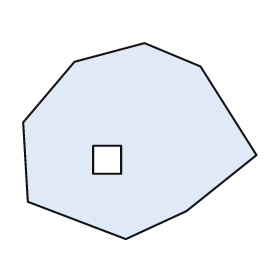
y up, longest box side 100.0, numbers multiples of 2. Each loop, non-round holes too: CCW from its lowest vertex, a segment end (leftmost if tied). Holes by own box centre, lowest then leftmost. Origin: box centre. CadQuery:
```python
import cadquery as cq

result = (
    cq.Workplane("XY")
    .moveTo(-6.0, -42.0)
    .lineTo(20.0, -30.0)
    .lineTo(50.0, -6.0)
    .lineTo(26.0, 32.0)
    .lineTo(2.0, 42.0)
    .lineTo(-28.0, 34.0)
    .lineTo(-50.0, 8.0)
    .lineTo(-48.0, -26.0)
    .close()
    .moveTo(-20.0, -14.0)
    .lineTo(-8.0, -14.0)
    .lineTo(-8.0, -2.0)
    .lineTo(-20.0, -2.0)
    .close()
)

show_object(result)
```